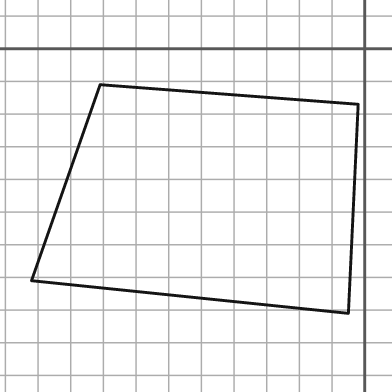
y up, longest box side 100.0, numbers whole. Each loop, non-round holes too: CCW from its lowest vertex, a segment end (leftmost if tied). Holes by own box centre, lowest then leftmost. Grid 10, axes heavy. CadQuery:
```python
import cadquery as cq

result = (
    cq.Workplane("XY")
    .moveTo(-5.0, -81.0)
    .lineTo(-2.0, -17.0)
    .lineTo(-81.0, -11.0)
    .lineTo(-102.0, -71.0)
    .close()
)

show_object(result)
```